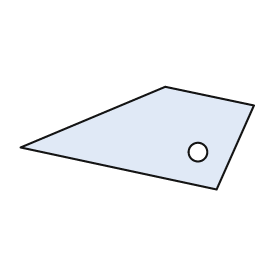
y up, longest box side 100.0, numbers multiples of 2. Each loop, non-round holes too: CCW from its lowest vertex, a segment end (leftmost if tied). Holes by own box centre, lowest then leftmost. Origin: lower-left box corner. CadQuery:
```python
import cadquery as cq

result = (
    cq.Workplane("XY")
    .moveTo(84.0, 0.0)
    .lineTo(100.0, 36.0)
    .lineTo(62.0, 44.0)
    .lineTo(0.0, 18.0)
    .close()
    .moveTo(76.0, 16.0)
    .circle(4.0)
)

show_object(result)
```